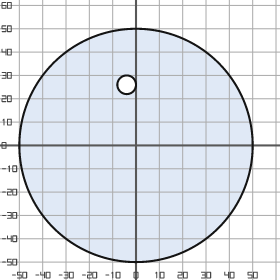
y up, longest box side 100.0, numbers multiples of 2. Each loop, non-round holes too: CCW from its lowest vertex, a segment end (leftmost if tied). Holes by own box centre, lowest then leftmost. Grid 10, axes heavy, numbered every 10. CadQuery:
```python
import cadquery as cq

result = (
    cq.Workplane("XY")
    .moveTo(0.0, 0.0)
    .circle(50.0)
    .moveTo(-4.0, 26.0)
    .circle(4.0)
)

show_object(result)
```